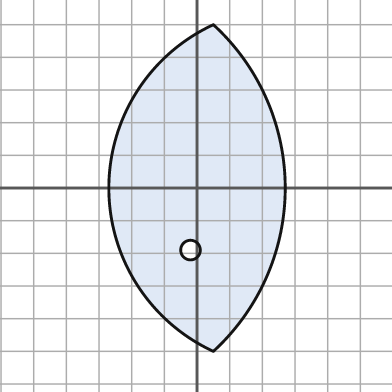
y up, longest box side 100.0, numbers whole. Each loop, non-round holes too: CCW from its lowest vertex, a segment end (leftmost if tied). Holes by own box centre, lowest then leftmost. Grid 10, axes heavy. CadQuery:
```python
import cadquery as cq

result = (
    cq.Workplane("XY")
    .moveTo(5.0, -50.0)
    .threePointArc((27.0, 0.0), (5.0, 50.0))
    .threePointArc((-27.0, 0.0), (5.0, -50.0))
    .close()
    .moveTo(-2.0, -19.0)
    .circle(3.0)
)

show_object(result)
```